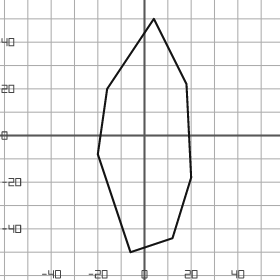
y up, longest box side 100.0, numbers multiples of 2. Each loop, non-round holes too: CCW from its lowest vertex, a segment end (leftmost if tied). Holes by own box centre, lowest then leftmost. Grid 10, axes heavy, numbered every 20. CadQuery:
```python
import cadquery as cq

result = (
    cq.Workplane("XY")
    .moveTo(-6.0, -50.0)
    .lineTo(12.0, -44.0)
    .lineTo(20.0, -18.0)
    .lineTo(18.0, 22.0)
    .lineTo(4.0, 50.0)
    .lineTo(-16.0, 20.0)
    .lineTo(-20.0, -8.0)
    .close()
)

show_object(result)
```